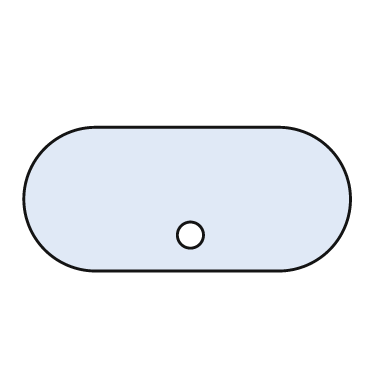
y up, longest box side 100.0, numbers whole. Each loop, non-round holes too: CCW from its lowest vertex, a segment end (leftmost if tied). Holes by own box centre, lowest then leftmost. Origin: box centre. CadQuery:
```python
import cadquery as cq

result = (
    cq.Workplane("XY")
    .moveTo(-28.0, -22.0)
    .lineTo(28.0, -22.0)
    .threePointArc((50.0, 0.0), (28.0, 22.0))
    .lineTo(-28.0, 22.0)
    .threePointArc((-50.0, 0.0), (-28.0, -22.0))
    .close()
    .moveTo(1.0, -11.0)
    .circle(4.0)
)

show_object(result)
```